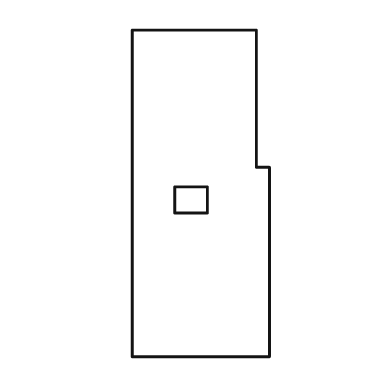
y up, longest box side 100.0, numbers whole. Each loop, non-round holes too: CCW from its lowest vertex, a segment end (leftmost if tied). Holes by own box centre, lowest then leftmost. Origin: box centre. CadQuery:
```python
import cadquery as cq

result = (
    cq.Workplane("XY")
    .moveTo(-21.0, -50.0)
    .lineTo(21.0, -50.0)
    .lineTo(21.0, 8.0)
    .lineTo(17.0, 8.0)
    .lineTo(17.0, 50.0)
    .lineTo(-21.0, 50.0)
    .close()
    .moveTo(-8.0, -6.0)
    .lineTo(2.0, -6.0)
    .lineTo(2.0, 2.0)
    .lineTo(-8.0, 2.0)
    .close()
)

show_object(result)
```